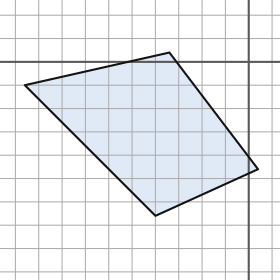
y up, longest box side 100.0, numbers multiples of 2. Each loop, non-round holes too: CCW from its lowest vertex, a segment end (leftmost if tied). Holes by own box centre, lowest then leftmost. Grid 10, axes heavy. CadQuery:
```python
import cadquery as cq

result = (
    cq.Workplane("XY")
    .moveTo(-40.0, -66.0)
    .lineTo(4.0, -46.0)
    .lineTo(-34.0, 4.0)
    .lineTo(-96.0, -10.0)
    .close()
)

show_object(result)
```